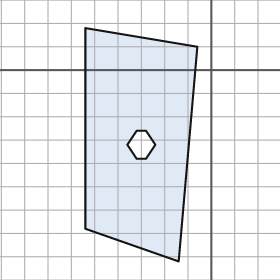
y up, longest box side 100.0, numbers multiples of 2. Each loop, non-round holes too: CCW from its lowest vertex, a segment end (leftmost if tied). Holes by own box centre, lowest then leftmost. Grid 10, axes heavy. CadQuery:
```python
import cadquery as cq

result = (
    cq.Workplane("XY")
    .moveTo(-14.0, -82.0)
    .lineTo(-6.0, 10.0)
    .lineTo(-54.0, 18.0)
    .lineTo(-54.0, -68.0)
    .close()
    .moveTo(-32.0, -38.0)
    .lineTo(-28.0, -38.0)
    .lineTo(-24.0, -32.0)
    .lineTo(-28.0, -26.0)
    .lineTo(-32.0, -26.0)
    .lineTo(-36.0, -32.0)
    .close()
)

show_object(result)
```